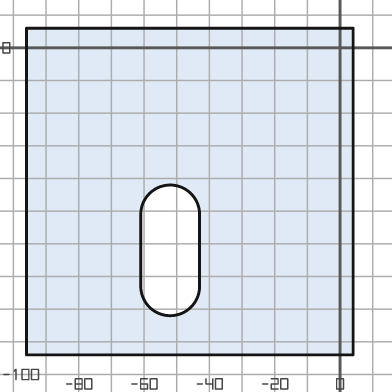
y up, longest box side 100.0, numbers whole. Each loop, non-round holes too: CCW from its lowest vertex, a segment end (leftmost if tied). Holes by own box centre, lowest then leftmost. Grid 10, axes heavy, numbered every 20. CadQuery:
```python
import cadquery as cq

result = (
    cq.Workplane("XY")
    .moveTo(-96.0, -94.0)
    .lineTo(4.0, -94.0)
    .lineTo(4.0, 6.0)
    .lineTo(-96.0, 6.0)
    .close()
    .moveTo(-61.0, -73.0)
    .threePointArc((-52.0, -82.0), (-43.0, -73.0))
    .lineTo(-43.0, -51.0)
    .threePointArc((-52.0, -42.0), (-61.0, -51.0))
    .close()
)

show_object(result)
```